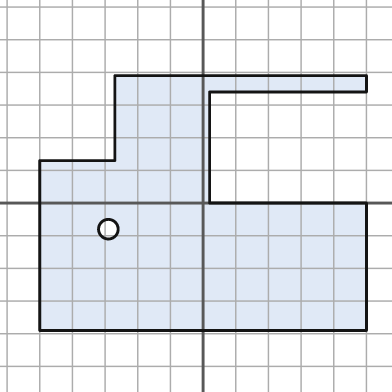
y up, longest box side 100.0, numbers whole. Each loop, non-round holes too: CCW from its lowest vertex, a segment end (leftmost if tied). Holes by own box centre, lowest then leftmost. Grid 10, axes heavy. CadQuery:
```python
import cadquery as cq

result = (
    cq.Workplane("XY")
    .moveTo(-50.0, -39.0)
    .lineTo(50.0, -39.0)
    .lineTo(50.0, 0.0)
    .lineTo(2.0, 0.0)
    .lineTo(2.0, 34.0)
    .lineTo(50.0, 34.0)
    .lineTo(50.0, 39.0)
    .lineTo(-27.0, 39.0)
    .lineTo(-27.0, 13.0)
    .lineTo(-50.0, 13.0)
    .close()
    .moveTo(-29.0, -8.0)
    .circle(3.0)
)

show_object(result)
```